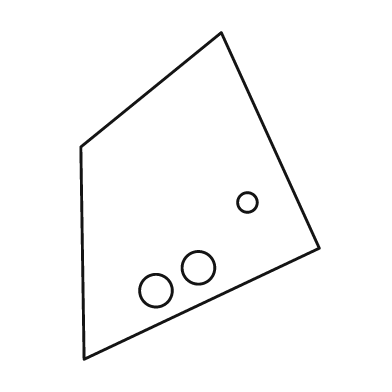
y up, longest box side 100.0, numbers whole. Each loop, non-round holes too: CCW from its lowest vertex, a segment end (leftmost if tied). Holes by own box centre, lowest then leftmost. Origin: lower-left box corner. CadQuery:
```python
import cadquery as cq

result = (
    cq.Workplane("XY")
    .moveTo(1.0, 0.0)
    .lineTo(73.0, 34.0)
    .lineTo(43.0, 100.0)
    .lineTo(0.0, 65.0)
    .close()
    .moveTo(23.0, 21.0)
    .circle(5.0)
    .moveTo(36.0, 28.0)
    .circle(5.0)
    .moveTo(51.0, 48.0)
    .circle(3.0)
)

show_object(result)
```